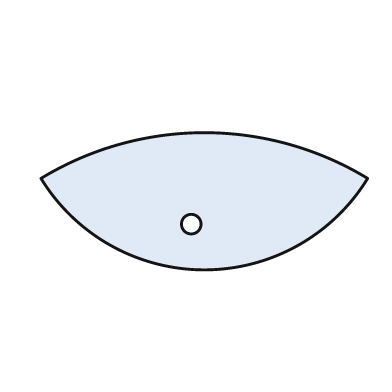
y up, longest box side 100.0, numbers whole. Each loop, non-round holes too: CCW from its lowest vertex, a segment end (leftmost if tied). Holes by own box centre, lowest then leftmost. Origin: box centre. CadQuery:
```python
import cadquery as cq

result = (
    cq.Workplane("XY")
    .moveTo(-50.0, 7.0)
    .threePointArc((0.0, -21.0), (50.0, 7.0))
    .threePointArc((0.0, 21.0), (-50.0, 7.0))
    .close()
    .moveTo(-4.0, -7.0)
    .circle(3.0)
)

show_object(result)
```